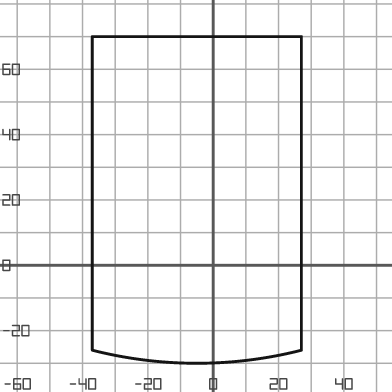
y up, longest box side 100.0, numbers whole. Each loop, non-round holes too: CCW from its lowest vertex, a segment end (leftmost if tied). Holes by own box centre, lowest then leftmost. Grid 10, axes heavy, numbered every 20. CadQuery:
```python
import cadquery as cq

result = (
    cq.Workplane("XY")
    .moveTo(-37.0, -26.0)
    .threePointArc((-5.0, -30.0), (27.0, -26.0))
    .lineTo(27.0, 70.0)
    .lineTo(-37.0, 70.0)
    .close()
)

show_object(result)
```